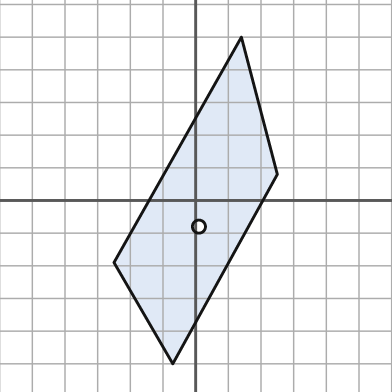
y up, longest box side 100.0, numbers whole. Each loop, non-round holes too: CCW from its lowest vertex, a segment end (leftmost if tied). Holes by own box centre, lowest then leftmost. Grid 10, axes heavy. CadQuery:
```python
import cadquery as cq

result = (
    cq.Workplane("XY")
    .moveTo(-7.0, -50.0)
    .lineTo(25.0, 8.0)
    .lineTo(14.0, 50.0)
    .lineTo(-25.0, -19.0)
    .close()
    .moveTo(1.0, -8.0)
    .circle(2.0)
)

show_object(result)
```